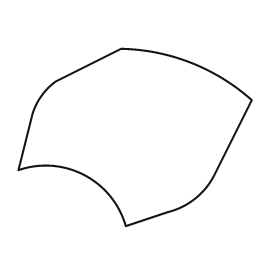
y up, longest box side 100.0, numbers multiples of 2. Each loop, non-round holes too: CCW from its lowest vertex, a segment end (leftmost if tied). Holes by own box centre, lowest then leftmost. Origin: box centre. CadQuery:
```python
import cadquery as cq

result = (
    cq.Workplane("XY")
    .moveTo(-4.0, -38.0)
    .lineTo(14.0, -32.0)
    .threePointArc((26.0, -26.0), (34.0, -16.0))
    .lineTo(50.0, 16.0)
    .threePointArc((24.0, 32.0), (-6.0, 38.0))
    .lineTo(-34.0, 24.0)
    .threePointArc((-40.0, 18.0), (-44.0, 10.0))
    .lineTo(-50.0, -14.0)
    .threePointArc((-22.0, -16.0), (-4.0, -38.0))
    .close()
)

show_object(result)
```